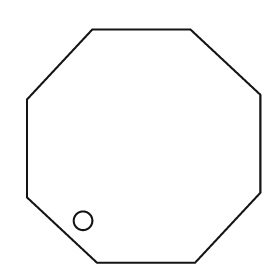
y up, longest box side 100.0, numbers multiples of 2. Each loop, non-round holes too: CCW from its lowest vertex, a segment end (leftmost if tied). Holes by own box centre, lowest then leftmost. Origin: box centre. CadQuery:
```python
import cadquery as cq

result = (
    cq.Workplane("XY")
    .moveTo(-20.0, -50.0)
    .lineTo(22.0, -50.0)
    .lineTo(50.0, -20.0)
    .lineTo(50.0, 22.0)
    .lineTo(20.0, 50.0)
    .lineTo(-22.0, 50.0)
    .lineTo(-50.0, 20.0)
    .lineTo(-50.0, -22.0)
    .close()
    .moveTo(-26.0, -32.0)
    .circle(4.0)
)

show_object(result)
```